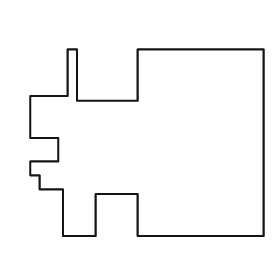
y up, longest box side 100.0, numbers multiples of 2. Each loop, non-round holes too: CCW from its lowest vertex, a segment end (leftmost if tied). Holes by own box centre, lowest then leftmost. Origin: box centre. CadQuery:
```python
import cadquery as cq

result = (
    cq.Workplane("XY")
    .moveTo(-36.0, -40.0)
    .lineTo(-22.0, -40.0)
    .lineTo(-22.0, -22.0)
    .lineTo(-4.0, -22.0)
    .lineTo(-4.0, -40.0)
    .lineTo(50.0, -40.0)
    .lineTo(50.0, 40.0)
    .lineTo(-4.0, 40.0)
    .lineTo(-4.0, 18.0)
    .lineTo(-30.0, 18.0)
    .lineTo(-30.0, 40.0)
    .lineTo(-34.0, 40.0)
    .lineTo(-34.0, 20.0)
    .lineTo(-50.0, 20.0)
    .lineTo(-50.0, 2.0)
    .lineTo(-38.0, 2.0)
    .lineTo(-38.0, -8.0)
    .lineTo(-50.0, -8.0)
    .lineTo(-50.0, -14.0)
    .lineTo(-46.0, -14.0)
    .lineTo(-46.0, -20.0)
    .lineTo(-36.0, -20.0)
    .close()
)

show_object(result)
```